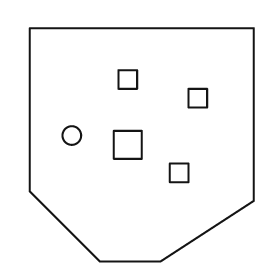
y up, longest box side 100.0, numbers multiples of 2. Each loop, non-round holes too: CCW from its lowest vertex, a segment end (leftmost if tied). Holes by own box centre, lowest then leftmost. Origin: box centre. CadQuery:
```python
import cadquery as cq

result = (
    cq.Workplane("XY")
    .moveTo(-18.0, -50.0)
    .lineTo(8.0, -50.0)
    .lineTo(48.0, -24.0)
    .lineTo(48.0, 50.0)
    .lineTo(-48.0, 50.0)
    .lineTo(-48.0, -20.0)
    .close()
    .moveTo(12.0, -16.0)
    .lineTo(20.0, -16.0)
    .lineTo(20.0, -8.0)
    .lineTo(12.0, -8.0)
    .close()
    .moveTo(-12.0, -6.0)
    .lineTo(0.0, -6.0)
    .lineTo(0.0, 6.0)
    .lineTo(-12.0, 6.0)
    .close()
    .moveTo(-30.0, 4.0)
    .circle(4.0)
    .moveTo(20.0, 16.0)
    .lineTo(28.0, 16.0)
    .lineTo(28.0, 24.0)
    .lineTo(20.0, 24.0)
    .close()
    .moveTo(-10.0, 24.0)
    .lineTo(-2.0, 24.0)
    .lineTo(-2.0, 32.0)
    .lineTo(-10.0, 32.0)
    .close()
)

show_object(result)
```